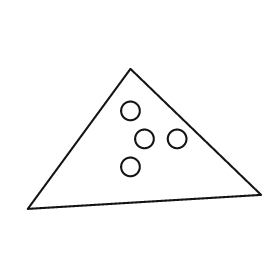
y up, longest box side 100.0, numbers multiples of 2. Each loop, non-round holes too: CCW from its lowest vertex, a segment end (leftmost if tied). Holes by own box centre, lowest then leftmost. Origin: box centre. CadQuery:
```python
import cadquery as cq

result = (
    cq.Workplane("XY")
    .moveTo(-50.0, -30.0)
    .lineTo(50.0, -24.0)
    .lineTo(-6.0, 30.0)
    .close()
    .moveTo(-6.0, -12.0)
    .circle(4.0)
    .moveTo(0.0, 0.0)
    .circle(4.0)
    .moveTo(14.0, 0.0)
    .circle(4.0)
    .moveTo(-6.0, 12.0)
    .circle(4.0)
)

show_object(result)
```